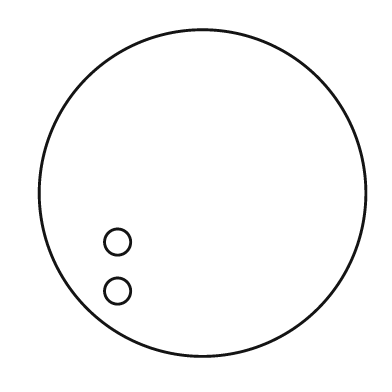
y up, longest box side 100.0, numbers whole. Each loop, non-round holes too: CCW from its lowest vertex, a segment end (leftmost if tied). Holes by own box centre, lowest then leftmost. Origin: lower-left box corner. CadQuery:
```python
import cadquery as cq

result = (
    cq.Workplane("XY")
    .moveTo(50.0, 50.0)
    .circle(50.0)
    .moveTo(24.0, 20.0)
    .circle(4.0)
    .moveTo(24.0, 35.0)
    .circle(4.0)
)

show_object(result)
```